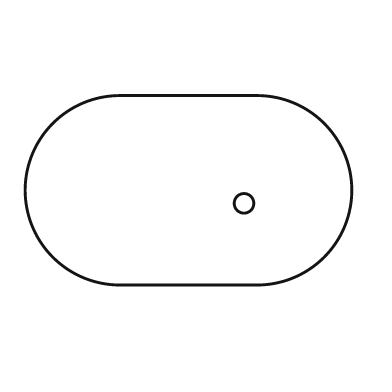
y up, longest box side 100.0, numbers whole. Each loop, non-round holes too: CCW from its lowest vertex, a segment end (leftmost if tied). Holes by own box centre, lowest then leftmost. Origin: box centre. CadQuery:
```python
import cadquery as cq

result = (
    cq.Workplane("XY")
    .moveTo(-21.0, -29.0)
    .lineTo(21.0, -29.0)
    .threePointArc((50.0, 0.0), (21.0, 29.0))
    .lineTo(-21.0, 29.0)
    .threePointArc((-50.0, 0.0), (-21.0, -29.0))
    .close()
    .moveTo(17.0, -4.0)
    .circle(3.0)
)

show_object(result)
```